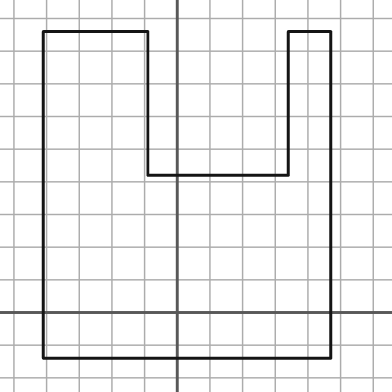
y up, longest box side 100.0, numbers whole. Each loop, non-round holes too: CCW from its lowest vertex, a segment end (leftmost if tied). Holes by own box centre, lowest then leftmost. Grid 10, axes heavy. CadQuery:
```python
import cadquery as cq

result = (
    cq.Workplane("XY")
    .moveTo(-41.0, -14.0)
    .lineTo(47.0, -14.0)
    .lineTo(47.0, 86.0)
    .lineTo(34.0, 86.0)
    .lineTo(34.0, 42.0)
    .lineTo(-9.0, 42.0)
    .lineTo(-9.0, 86.0)
    .lineTo(-41.0, 86.0)
    .close()
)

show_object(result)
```